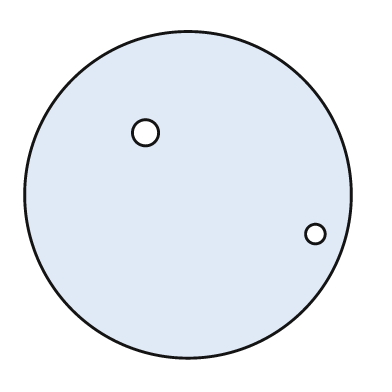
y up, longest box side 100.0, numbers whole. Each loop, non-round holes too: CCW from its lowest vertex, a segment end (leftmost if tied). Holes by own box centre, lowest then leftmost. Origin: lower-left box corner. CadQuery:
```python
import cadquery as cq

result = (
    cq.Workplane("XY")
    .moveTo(50.0, 50.0)
    .circle(50.0)
    .moveTo(89.0, 38.0)
    .circle(3.0)
    .moveTo(37.0, 69.0)
    .circle(4.0)
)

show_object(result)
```